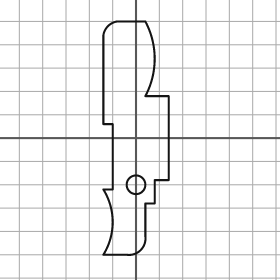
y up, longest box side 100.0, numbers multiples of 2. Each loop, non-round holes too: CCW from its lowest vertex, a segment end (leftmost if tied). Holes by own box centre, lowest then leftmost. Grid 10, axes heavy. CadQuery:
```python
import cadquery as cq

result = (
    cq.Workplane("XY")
    .moveTo(-14.0, -50.0)
    .lineTo(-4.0, -50.0)
    .threePointArc((2.0, -48.0), (4.0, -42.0))
    .lineTo(4.0, -28.0)
    .lineTo(8.0, -28.0)
    .lineTo(8.0, -18.0)
    .lineTo(14.0, -18.0)
    .lineTo(14.0, 18.0)
    .lineTo(4.0, 18.0)
    .threePointArc((8.0, 34.0), (4.0, 50.0))
    .lineTo(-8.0, 50.0)
    .threePointArc((-12.0, 48.0), (-14.0, 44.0))
    .lineTo(-14.0, 6.0)
    .lineTo(-10.0, 6.0)
    .lineTo(-10.0, -22.0)
    .lineTo(-14.0, -22.0)
    .threePointArc((-10.0, -36.0), (-14.0, -50.0))
    .close()
    .moveTo(0.0, -20.0)
    .circle(4.0)
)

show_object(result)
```